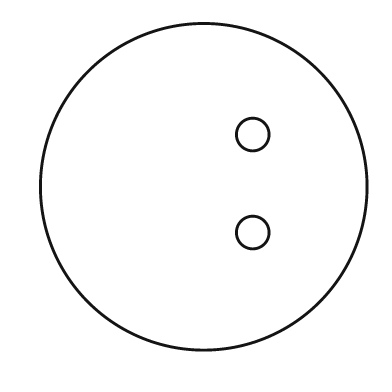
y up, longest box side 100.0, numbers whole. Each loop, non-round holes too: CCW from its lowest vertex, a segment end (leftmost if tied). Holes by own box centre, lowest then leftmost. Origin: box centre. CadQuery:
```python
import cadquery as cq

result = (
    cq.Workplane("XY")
    .moveTo(0.0, 0.0)
    .circle(50.0)
    .moveTo(15.0, -14.0)
    .circle(5.0)
    .moveTo(15.0, 16.0)
    .circle(5.0)
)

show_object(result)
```